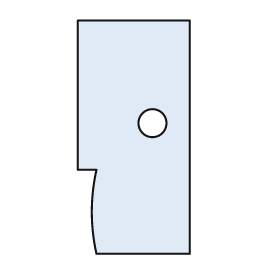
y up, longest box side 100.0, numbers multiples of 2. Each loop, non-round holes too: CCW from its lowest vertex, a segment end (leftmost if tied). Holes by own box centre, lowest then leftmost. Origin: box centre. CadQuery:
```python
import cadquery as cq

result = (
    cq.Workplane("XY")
    .moveTo(-16.0, -50.0)
    .lineTo(24.0, -50.0)
    .lineTo(24.0, 50.0)
    .lineTo(-24.0, 50.0)
    .lineTo(-24.0, -14.0)
    .lineTo(-16.0, -14.0)
    .threePointArc((-18.0, -32.0), (-16.0, -50.0))
    .close()
    .moveTo(8.0, 6.0)
    .circle(6.0)
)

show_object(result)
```